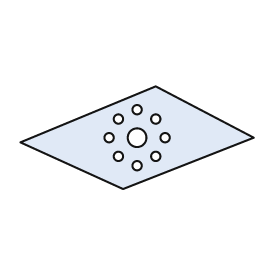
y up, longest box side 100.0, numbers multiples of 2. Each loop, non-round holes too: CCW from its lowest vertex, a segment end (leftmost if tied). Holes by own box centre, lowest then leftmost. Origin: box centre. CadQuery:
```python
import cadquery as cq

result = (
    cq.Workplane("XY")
    .moveTo(-6.0, -22.0)
    .lineTo(50.0, 0.0)
    .lineTo(8.0, 22.0)
    .lineTo(-50.0, -2.0)
    .close()
    .moveTo(0.0, -12.0)
    .circle(2.0)
    .moveTo(-8.0, -8.0)
    .circle(2.0)
    .moveTo(8.0, -8.0)
    .circle(2.0)
    .moveTo(-12.0, 0.0)
    .circle(2.0)
    .moveTo(0.0, 0.0)
    .circle(4.0)
    .moveTo(12.0, 0.0)
    .circle(2.0)
    .moveTo(-8.0, 8.0)
    .circle(2.0)
    .moveTo(8.0, 8.0)
    .circle(2.0)
    .moveTo(0.0, 12.0)
    .circle(2.0)
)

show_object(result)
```